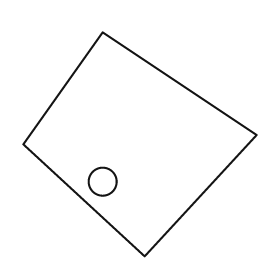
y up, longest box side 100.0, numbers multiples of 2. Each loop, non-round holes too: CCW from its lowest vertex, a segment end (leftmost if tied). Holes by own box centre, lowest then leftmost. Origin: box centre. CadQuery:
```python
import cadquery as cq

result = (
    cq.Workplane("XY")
    .moveTo(2.0, -48.0)
    .lineTo(50.0, 4.0)
    .lineTo(-16.0, 48.0)
    .lineTo(-50.0, 0.0)
    .close()
    .moveTo(-16.0, -16.0)
    .circle(6.0)
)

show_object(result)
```